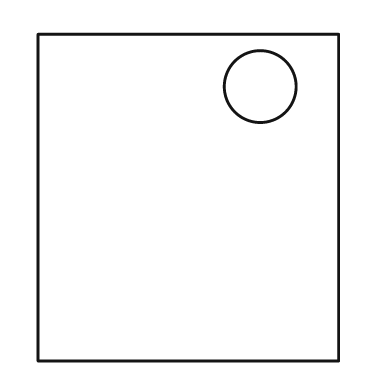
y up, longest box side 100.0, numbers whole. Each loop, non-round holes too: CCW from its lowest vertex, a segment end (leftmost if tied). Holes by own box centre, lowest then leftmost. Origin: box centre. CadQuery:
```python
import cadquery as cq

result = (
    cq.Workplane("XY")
    .moveTo(-46.0, -50.0)
    .lineTo(46.0, -50.0)
    .lineTo(46.0, 50.0)
    .lineTo(-46.0, 50.0)
    .close()
    .moveTo(22.0, 34.0)
    .circle(11.0)
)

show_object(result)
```